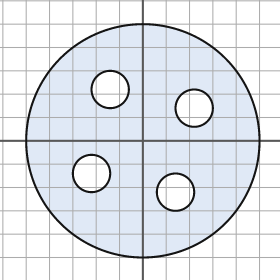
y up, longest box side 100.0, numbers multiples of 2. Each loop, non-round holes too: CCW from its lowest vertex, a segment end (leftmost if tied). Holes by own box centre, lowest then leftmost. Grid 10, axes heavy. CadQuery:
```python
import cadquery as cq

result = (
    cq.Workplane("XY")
    .moveTo(0.0, 0.0)
    .circle(50.0)
    .moveTo(14.0, -22.0)
    .circle(8.0)
    .moveTo(-22.0, -14.0)
    .circle(8.0)
    .moveTo(22.0, 14.0)
    .circle(8.0)
    .moveTo(-14.0, 22.0)
    .circle(8.0)
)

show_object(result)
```